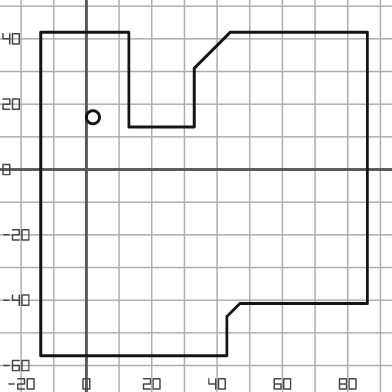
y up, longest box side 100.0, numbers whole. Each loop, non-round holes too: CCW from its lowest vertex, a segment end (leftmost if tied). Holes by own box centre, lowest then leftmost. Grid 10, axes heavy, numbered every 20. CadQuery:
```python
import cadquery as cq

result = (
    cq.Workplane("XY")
    .moveTo(-14.0, -57.0)
    .lineTo(43.0, -57.0)
    .lineTo(43.0, -45.0)
    .lineTo(47.0, -41.0)
    .lineTo(86.0, -41.0)
    .lineTo(86.0, 42.0)
    .lineTo(44.0, 42.0)
    .lineTo(33.0, 31.0)
    .lineTo(33.0, 13.0)
    .lineTo(13.0, 13.0)
    .lineTo(13.0, 42.0)
    .lineTo(-14.0, 42.0)
    .close()
    .moveTo(2.0, 16.0)
    .circle(2.0)
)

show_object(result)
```